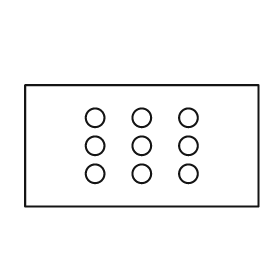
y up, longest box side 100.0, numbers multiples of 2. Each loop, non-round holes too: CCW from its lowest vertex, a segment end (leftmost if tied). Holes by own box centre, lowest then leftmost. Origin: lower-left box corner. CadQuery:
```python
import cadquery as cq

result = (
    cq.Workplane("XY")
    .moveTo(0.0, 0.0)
    .lineTo(100.0, 0.0)
    .lineTo(100.0, 52.0)
    .lineTo(0.0, 52.0)
    .close()
    .moveTo(30.0, 14.0)
    .circle(4.0)
    .moveTo(50.0, 14.0)
    .circle(4.0)
    .moveTo(70.0, 14.0)
    .circle(4.0)
    .moveTo(30.0, 26.0)
    .circle(4.0)
    .moveTo(50.0, 26.0)
    .circle(4.0)
    .moveTo(70.0, 26.0)
    .circle(4.0)
    .moveTo(30.0, 38.0)
    .circle(4.0)
    .moveTo(50.0, 38.0)
    .circle(4.0)
    .moveTo(70.0, 38.0)
    .circle(4.0)
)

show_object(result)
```